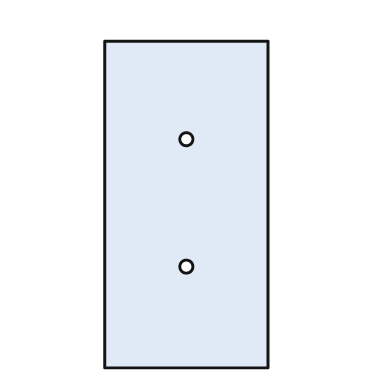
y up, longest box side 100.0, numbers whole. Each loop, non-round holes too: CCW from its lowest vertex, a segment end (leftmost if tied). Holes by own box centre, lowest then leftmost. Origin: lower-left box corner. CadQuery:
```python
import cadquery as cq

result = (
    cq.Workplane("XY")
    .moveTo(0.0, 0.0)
    .lineTo(50.0, 0.0)
    .lineTo(50.0, 100.0)
    .lineTo(0.0, 100.0)
    .close()
    .moveTo(25.0, 31.0)
    .circle(2.0)
    .moveTo(25.0, 70.0)
    .circle(2.0)
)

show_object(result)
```